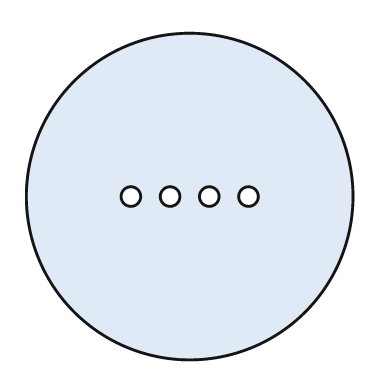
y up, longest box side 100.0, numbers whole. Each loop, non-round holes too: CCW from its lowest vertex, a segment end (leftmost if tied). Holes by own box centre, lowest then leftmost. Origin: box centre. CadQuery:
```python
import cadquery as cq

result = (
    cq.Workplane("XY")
    .moveTo(0.0, 0.0)
    .circle(50.0)
    .moveTo(-18.0, 0.0)
    .circle(3.0)
    .moveTo(-6.0, 0.0)
    .circle(3.0)
    .moveTo(6.0, 0.0)
    .circle(3.0)
    .moveTo(18.0, 0.0)
    .circle(3.0)
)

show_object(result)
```